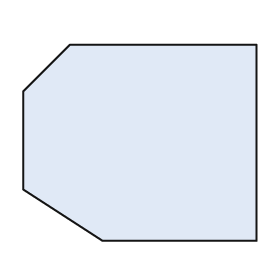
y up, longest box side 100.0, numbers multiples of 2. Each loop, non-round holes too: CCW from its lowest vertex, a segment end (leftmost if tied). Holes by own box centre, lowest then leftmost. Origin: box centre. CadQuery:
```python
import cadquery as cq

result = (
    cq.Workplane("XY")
    .moveTo(-16.0, -42.0)
    .lineTo(50.0, -42.0)
    .lineTo(50.0, 42.0)
    .lineTo(-30.0, 42.0)
    .lineTo(-50.0, 22.0)
    .lineTo(-50.0, -20.0)
    .close()
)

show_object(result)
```